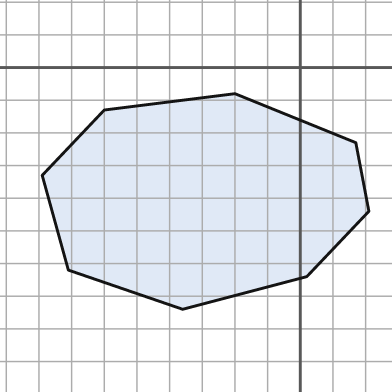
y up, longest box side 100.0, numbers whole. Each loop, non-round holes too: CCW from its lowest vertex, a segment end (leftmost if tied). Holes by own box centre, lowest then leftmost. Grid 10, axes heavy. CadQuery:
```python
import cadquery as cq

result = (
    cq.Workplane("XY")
    .moveTo(-36.0, -74.0)
    .lineTo(2.0, -64.0)
    .lineTo(21.0, -44.0)
    .lineTo(17.0, -23.0)
    .lineTo(-20.0, -8.0)
    .lineTo(-60.0, -13.0)
    .lineTo(-79.0, -33.0)
    .lineTo(-71.0, -62.0)
    .close()
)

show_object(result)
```